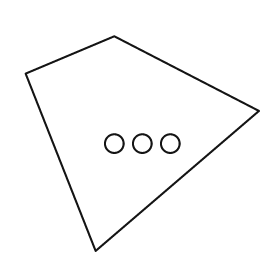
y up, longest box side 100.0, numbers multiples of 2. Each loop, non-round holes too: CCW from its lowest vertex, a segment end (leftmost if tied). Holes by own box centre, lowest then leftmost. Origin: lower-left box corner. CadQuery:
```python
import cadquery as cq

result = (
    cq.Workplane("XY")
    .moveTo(30.0, 0.0)
    .lineTo(100.0, 60.0)
    .lineTo(38.0, 92.0)
    .lineTo(0.0, 76.0)
    .close()
    .moveTo(38.0, 46.0)
    .circle(4.0)
    .moveTo(50.0, 46.0)
    .circle(4.0)
    .moveTo(62.0, 46.0)
    .circle(4.0)
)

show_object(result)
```